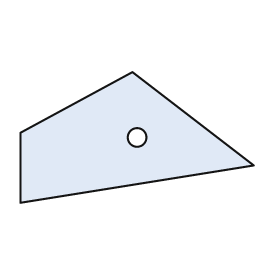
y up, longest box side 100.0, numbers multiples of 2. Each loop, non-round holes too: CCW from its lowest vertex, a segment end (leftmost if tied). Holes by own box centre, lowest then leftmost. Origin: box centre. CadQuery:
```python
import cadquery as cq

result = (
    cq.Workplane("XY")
    .moveTo(-50.0, -28.0)
    .lineTo(50.0, -12.0)
    .lineTo(-2.0, 28.0)
    .lineTo(-50.0, 2.0)
    .close()
    .moveTo(0.0, 0.0)
    .circle(4.0)
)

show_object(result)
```